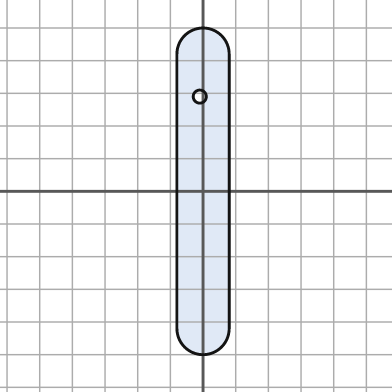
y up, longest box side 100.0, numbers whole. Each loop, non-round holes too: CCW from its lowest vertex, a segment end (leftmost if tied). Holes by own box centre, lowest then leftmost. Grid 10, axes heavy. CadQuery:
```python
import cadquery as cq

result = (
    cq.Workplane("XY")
    .moveTo(-8.0, -42.0)
    .threePointArc((0.0, -50.0), (8.0, -42.0))
    .lineTo(8.0, 42.0)
    .threePointArc((0.0, 50.0), (-8.0, 42.0))
    .close()
    .moveTo(-1.0, 29.0)
    .circle(2.0)
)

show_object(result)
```